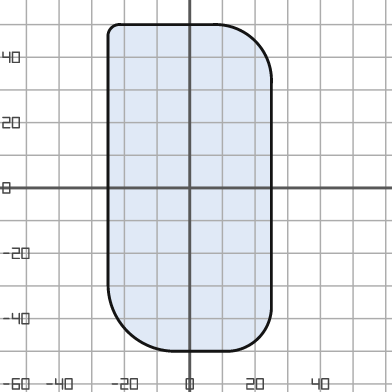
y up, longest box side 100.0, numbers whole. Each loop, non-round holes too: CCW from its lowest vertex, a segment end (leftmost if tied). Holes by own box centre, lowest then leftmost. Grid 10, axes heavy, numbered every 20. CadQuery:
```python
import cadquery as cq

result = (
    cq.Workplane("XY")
    .moveTo(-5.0, -50.0)
    .lineTo(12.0, -50.0)
    .threePointArc((21.0, -46.0), (25.0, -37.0))
    .lineTo(25.0, 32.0)
    .threePointArc((20.0, 45.0), (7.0, 50.0))
    .lineTo(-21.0, 50.0)
    .threePointArc((-24.0, 49.0), (-25.0, 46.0))
    .lineTo(-25.0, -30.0)
    .threePointArc((-19.0, -44.0), (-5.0, -50.0))
    .close()
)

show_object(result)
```